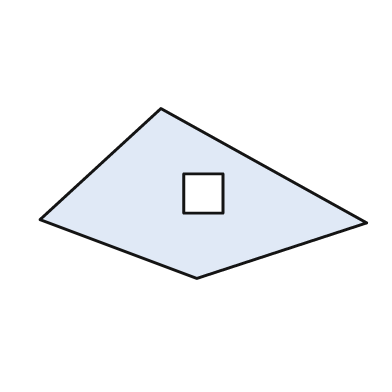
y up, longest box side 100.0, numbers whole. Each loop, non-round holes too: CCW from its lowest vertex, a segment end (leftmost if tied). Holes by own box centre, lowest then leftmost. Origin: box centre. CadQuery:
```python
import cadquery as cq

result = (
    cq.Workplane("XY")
    .moveTo(-2.0, -26.0)
    .lineTo(50.0, -9.0)
    .lineTo(-13.0, 26.0)
    .lineTo(-50.0, -8.0)
    .close()
    .moveTo(-6.0, -6.0)
    .lineTo(6.0, -6.0)
    .lineTo(6.0, 6.0)
    .lineTo(-6.0, 6.0)
    .close()
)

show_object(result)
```